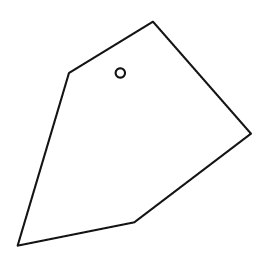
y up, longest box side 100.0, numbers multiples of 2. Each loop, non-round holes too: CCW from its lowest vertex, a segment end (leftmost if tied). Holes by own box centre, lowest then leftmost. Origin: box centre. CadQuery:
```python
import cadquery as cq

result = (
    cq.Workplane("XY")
    .moveTo(-50.0, -48.0)
    .lineTo(0.0, -38.0)
    .lineTo(50.0, 0.0)
    .lineTo(8.0, 48.0)
    .lineTo(-28.0, 26.0)
    .close()
    .moveTo(-6.0, 26.0)
    .circle(2.0)
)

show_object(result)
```